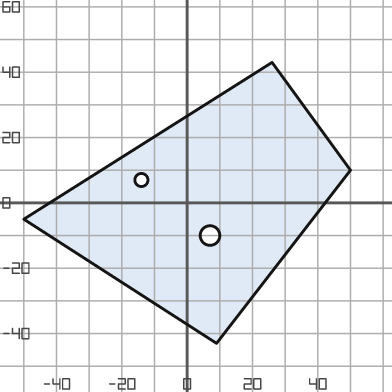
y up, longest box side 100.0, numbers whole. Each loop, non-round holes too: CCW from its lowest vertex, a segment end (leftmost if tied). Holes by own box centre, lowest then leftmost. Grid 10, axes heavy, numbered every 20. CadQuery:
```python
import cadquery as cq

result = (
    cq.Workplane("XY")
    .moveTo(9.0, -43.0)
    .lineTo(50.0, 10.0)
    .lineTo(26.0, 43.0)
    .lineTo(-50.0, -5.0)
    .close()
    .moveTo(7.0, -10.0)
    .circle(3.0)
    .moveTo(-14.0, 7.0)
    .circle(2.0)
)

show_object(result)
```